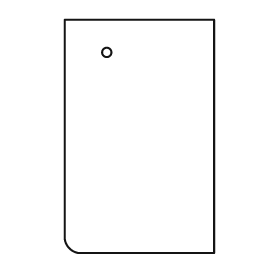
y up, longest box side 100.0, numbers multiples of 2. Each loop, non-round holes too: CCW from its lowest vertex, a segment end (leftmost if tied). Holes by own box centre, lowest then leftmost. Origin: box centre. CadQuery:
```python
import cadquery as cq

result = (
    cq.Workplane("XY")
    .moveTo(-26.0, -50.0)
    .lineTo(32.0, -50.0)
    .lineTo(32.0, 50.0)
    .lineTo(-32.0, 50.0)
    .lineTo(-32.0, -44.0)
    .threePointArc((-30.0, -48.0), (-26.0, -50.0))
    .close()
    .moveTo(-14.0, 36.0)
    .circle(2.0)
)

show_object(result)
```